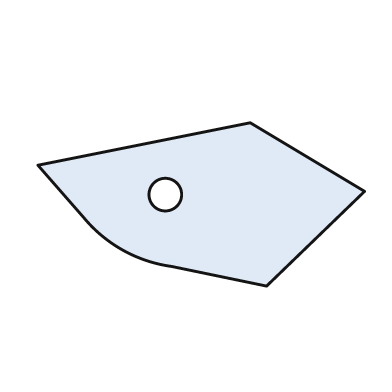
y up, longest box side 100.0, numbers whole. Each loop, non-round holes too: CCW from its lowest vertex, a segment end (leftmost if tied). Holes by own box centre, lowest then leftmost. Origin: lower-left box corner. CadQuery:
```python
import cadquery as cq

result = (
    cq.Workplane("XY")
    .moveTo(70.0, 0.0)
    .lineTo(100.0, 29.0)
    .lineTo(65.0, 50.0)
    .lineTo(0.0, 37.0)
    .lineTo(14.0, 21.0)
    .threePointArc((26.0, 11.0), (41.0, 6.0))
    .close()
    .moveTo(39.0, 28.0)
    .circle(5.0)
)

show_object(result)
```